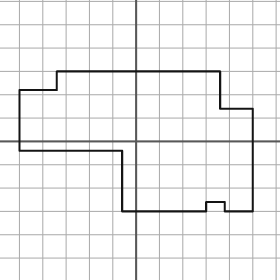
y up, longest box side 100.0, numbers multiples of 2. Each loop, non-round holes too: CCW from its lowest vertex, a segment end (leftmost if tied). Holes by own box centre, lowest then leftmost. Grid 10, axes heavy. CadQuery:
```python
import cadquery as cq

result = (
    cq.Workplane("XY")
    .moveTo(-6.0, -30.0)
    .lineTo(30.0, -30.0)
    .lineTo(30.0, -26.0)
    .lineTo(38.0, -26.0)
    .lineTo(38.0, -30.0)
    .lineTo(50.0, -30.0)
    .lineTo(50.0, 14.0)
    .lineTo(36.0, 14.0)
    .lineTo(36.0, 30.0)
    .lineTo(-34.0, 30.0)
    .lineTo(-34.0, 22.0)
    .lineTo(-50.0, 22.0)
    .lineTo(-50.0, -4.0)
    .lineTo(-6.0, -4.0)
    .close()
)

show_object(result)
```